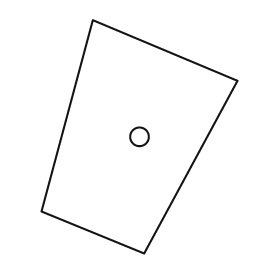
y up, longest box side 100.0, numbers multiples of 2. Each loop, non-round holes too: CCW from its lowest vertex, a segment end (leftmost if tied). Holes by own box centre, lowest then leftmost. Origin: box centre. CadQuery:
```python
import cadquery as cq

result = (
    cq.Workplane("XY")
    .moveTo(2.0, -50.0)
    .lineTo(42.0, 24.0)
    .lineTo(-20.0, 50.0)
    .lineTo(-42.0, -32.0)
    .close()
    .moveTo(0.0, 0.0)
    .circle(4.0)
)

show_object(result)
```